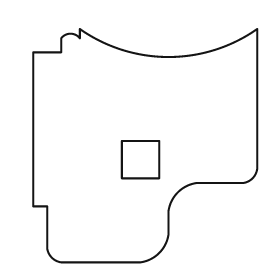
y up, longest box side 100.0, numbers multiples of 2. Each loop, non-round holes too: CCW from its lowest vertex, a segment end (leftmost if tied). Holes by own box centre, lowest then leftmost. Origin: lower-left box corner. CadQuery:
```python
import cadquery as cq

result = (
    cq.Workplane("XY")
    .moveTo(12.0, 0.0)
    .lineTo(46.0, 0.0)
    .threePointArc((54.0, 4.0), (58.0, 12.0))
    .lineTo(58.0, 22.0)
    .threePointArc((62.0, 30.0), (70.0, 34.0))
    .lineTo(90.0, 34.0)
    .threePointArc((94.0, 36.0), (96.0, 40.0))
    .lineTo(96.0, 100.0)
    .threePointArc((58.0, 88.0), (20.0, 100.0))
    .lineTo(20.0, 96.0)
    .threePointArc((16.0, 98.0), (12.0, 96.0))
    .lineTo(12.0, 90.0)
    .lineTo(0.0, 90.0)
    .lineTo(0.0, 24.0)
    .lineTo(6.0, 24.0)
    .lineTo(6.0, 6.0)
    .threePointArc((8.0, 2.0), (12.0, 0.0))
    .close()
    .moveTo(38.0, 36.0)
    .lineTo(54.0, 36.0)
    .lineTo(54.0, 52.0)
    .lineTo(38.0, 52.0)
    .close()
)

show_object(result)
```